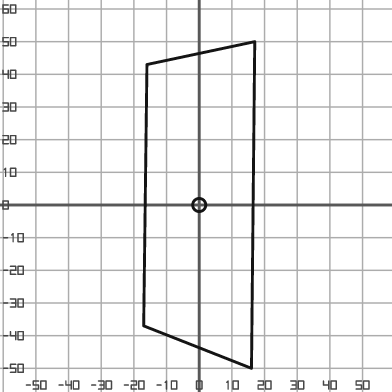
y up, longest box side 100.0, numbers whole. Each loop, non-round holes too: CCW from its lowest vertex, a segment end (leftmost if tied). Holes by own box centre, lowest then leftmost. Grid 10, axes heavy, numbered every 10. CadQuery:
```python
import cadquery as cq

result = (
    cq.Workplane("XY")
    .moveTo(16.0, -50.0)
    .lineTo(17.0, 50.0)
    .lineTo(-16.0, 43.0)
    .lineTo(-17.0, -37.0)
    .close()
    .moveTo(0.0, 0.0)
    .circle(2.0)
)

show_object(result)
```